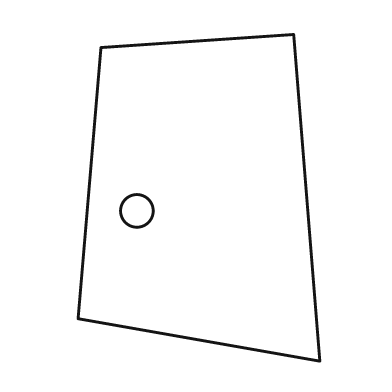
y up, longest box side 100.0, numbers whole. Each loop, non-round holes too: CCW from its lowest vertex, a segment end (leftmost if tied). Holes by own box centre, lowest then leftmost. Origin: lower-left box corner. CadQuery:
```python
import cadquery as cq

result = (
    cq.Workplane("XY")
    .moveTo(74.0, 0.0)
    .lineTo(66.0, 100.0)
    .lineTo(7.0, 96.0)
    .lineTo(0.0, 13.0)
    .close()
    .moveTo(18.0, 46.0)
    .circle(5.0)
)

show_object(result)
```